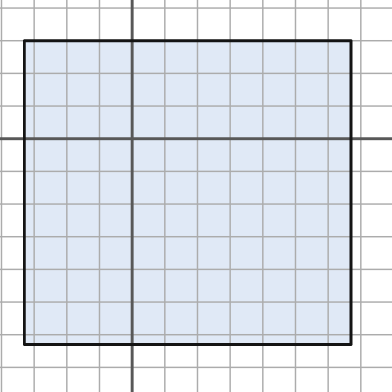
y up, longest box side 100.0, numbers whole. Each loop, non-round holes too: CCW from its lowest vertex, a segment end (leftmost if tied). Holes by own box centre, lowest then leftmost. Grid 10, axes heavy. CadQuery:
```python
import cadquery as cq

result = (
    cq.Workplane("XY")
    .moveTo(-33.0, -63.0)
    .lineTo(67.0, -63.0)
    .lineTo(67.0, 30.0)
    .lineTo(-33.0, 30.0)
    .close()
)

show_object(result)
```